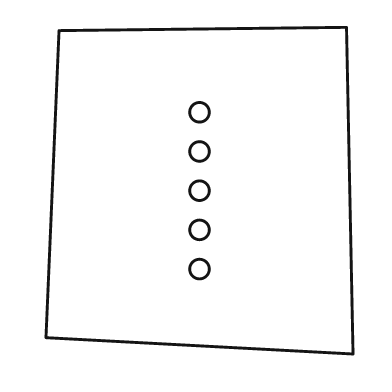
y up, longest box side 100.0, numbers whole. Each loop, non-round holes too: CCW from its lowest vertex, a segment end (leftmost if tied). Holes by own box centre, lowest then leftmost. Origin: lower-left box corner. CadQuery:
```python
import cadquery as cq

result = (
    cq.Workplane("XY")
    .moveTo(94.0, 0.0)
    .lineTo(92.0, 100.0)
    .lineTo(4.0, 99.0)
    .lineTo(0.0, 5.0)
    .close()
    .moveTo(47.0, 26.0)
    .circle(3.0)
    .moveTo(47.0, 38.0)
    .circle(3.0)
    .moveTo(47.0, 50.0)
    .circle(3.0)
    .moveTo(47.0, 62.0)
    .circle(3.0)
    .moveTo(47.0, 74.0)
    .circle(3.0)
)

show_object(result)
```